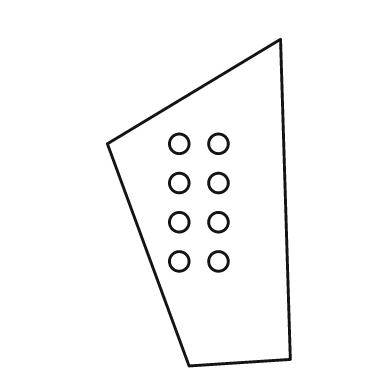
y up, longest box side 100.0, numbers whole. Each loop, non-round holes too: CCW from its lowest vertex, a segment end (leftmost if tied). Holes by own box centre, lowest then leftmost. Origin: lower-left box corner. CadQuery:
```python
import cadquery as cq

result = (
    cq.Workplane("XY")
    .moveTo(25.0, 0.0)
    .lineTo(56.0, 2.0)
    .lineTo(53.0, 100.0)
    .lineTo(0.0, 68.0)
    .close()
    .moveTo(22.0, 32.0)
    .circle(3.0)
    .moveTo(34.0, 32.0)
    .circle(3.0)
    .moveTo(22.0, 44.0)
    .circle(3.0)
    .moveTo(34.0, 44.0)
    .circle(3.0)
    .moveTo(22.0, 56.0)
    .circle(3.0)
    .moveTo(34.0, 56.0)
    .circle(3.0)
    .moveTo(22.0, 68.0)
    .circle(3.0)
    .moveTo(34.0, 68.0)
    .circle(3.0)
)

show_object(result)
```